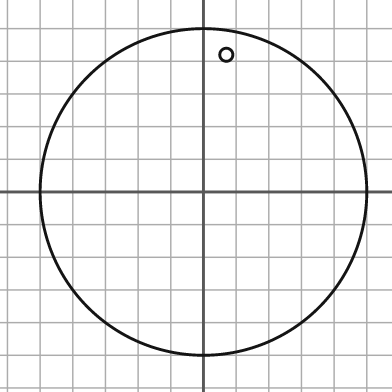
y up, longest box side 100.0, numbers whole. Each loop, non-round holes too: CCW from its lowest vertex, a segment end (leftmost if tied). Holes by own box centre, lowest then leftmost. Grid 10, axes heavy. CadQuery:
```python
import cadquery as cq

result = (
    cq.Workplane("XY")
    .moveTo(0.0, 0.0)
    .circle(50.0)
    .moveTo(7.0, 42.0)
    .circle(2.0)
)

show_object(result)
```